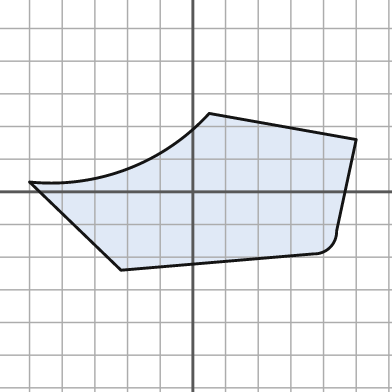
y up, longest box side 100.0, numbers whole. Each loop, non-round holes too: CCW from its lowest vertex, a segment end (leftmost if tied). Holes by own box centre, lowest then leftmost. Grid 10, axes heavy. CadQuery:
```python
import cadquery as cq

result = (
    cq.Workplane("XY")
    .moveTo(-22.0, -24.0)
    .lineTo(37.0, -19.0)
    .threePointArc((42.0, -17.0), (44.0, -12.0))
    .lineTo(50.0, 16.0)
    .lineTo(5.0, 24.0)
    .threePointArc((-20.0, 7.0), (-50.0, 3.0))
    .close()
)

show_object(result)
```